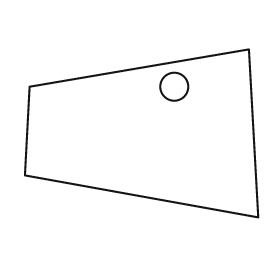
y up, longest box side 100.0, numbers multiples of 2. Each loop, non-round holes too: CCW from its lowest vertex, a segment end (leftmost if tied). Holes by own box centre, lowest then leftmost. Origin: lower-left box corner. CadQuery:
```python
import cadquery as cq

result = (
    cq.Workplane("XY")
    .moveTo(100.0, 0.0)
    .lineTo(96.0, 72.0)
    .lineTo(2.0, 56.0)
    .lineTo(0.0, 18.0)
    .close()
    .moveTo(64.0, 56.0)
    .circle(6.0)
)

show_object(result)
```